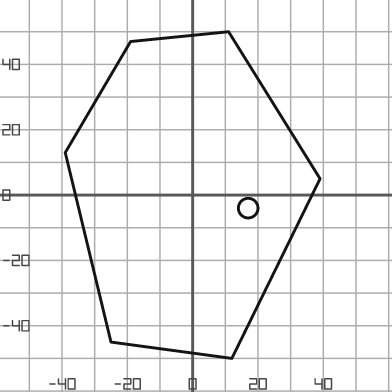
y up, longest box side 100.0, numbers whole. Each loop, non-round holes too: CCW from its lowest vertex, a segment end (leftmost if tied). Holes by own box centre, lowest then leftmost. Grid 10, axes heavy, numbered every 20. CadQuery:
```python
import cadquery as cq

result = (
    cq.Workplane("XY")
    .moveTo(12.0, -50.0)
    .lineTo(39.0, 5.0)
    .lineTo(11.0, 50.0)
    .lineTo(-19.0, 47.0)
    .lineTo(-39.0, 13.0)
    .lineTo(-25.0, -45.0)
    .close()
    .moveTo(17.0, -4.0)
    .circle(3.0)
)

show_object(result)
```